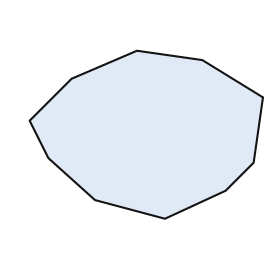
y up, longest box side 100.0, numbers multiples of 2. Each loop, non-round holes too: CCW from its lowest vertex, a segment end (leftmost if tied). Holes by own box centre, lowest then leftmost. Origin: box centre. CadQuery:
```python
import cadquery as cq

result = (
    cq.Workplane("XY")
    .moveTo(8.0, -36.0)
    .lineTo(34.0, -24.0)
    .lineTo(46.0, -12.0)
    .lineTo(50.0, 16.0)
    .lineTo(24.0, 32.0)
    .lineTo(-4.0, 36.0)
    .lineTo(-32.0, 24.0)
    .lineTo(-50.0, 6.0)
    .lineTo(-42.0, -10.0)
    .lineTo(-22.0, -28.0)
    .close()
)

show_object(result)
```